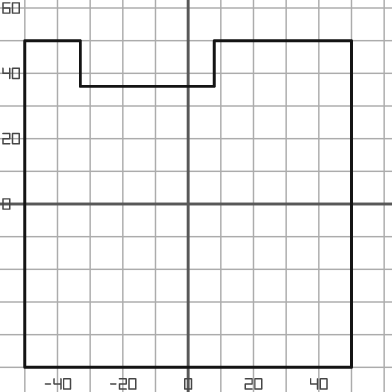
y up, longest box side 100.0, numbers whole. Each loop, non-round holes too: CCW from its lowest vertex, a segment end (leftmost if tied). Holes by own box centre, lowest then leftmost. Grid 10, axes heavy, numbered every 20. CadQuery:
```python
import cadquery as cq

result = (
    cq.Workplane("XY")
    .moveTo(-50.0, -50.0)
    .lineTo(50.0, -50.0)
    .lineTo(50.0, 50.0)
    .lineTo(8.0, 50.0)
    .lineTo(8.0, 36.0)
    .lineTo(-33.0, 36.0)
    .lineTo(-33.0, 50.0)
    .lineTo(-50.0, 50.0)
    .close()
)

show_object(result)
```